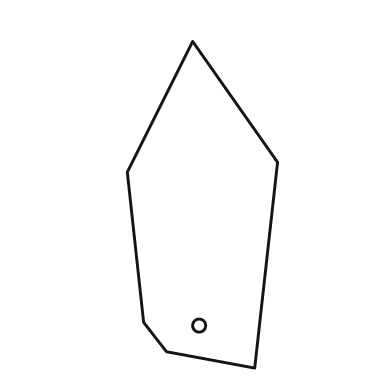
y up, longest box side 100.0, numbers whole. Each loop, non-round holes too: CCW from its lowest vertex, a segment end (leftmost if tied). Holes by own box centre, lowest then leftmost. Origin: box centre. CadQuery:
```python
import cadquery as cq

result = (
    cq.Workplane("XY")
    .moveTo(16.0, -50.0)
    .lineTo(23.0, 13.0)
    .lineTo(-3.0, 50.0)
    .lineTo(-23.0, 10.0)
    .lineTo(-18.0, -36.0)
    .lineTo(-11.0, -45.0)
    .close()
    .moveTo(-1.0, -37.0)
    .circle(2.0)
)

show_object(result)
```